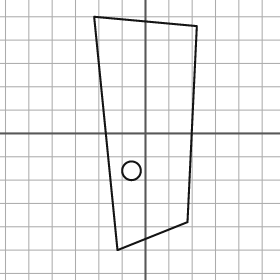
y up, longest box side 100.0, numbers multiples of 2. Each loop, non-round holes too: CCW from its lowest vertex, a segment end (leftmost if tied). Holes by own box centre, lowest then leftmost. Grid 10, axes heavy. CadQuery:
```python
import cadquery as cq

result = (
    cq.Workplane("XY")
    .moveTo(-12.0, -50.0)
    .lineTo(18.0, -38.0)
    .lineTo(22.0, 46.0)
    .lineTo(-22.0, 50.0)
    .close()
    .moveTo(-6.0, -16.0)
    .circle(4.0)
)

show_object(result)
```